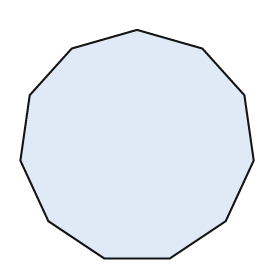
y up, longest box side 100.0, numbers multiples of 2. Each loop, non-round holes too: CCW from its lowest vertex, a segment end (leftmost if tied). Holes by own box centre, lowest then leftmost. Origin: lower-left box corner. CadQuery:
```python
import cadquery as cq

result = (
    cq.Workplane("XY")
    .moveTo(36.0, 0.0)
    .lineTo(64.0, 0.0)
    .lineTo(88.0, 16.0)
    .lineTo(100.0, 42.0)
    .lineTo(96.0, 70.0)
    .lineTo(78.0, 90.0)
    .lineTo(50.0, 98.0)
    .lineTo(22.0, 90.0)
    .lineTo(4.0, 70.0)
    .lineTo(0.0, 42.0)
    .lineTo(12.0, 16.0)
    .close()
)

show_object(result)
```